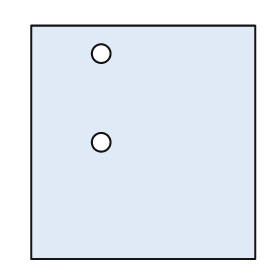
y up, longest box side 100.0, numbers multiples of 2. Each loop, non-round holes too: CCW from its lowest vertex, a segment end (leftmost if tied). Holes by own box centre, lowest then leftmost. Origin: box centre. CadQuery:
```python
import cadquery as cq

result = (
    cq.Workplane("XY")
    .moveTo(-48.0, -50.0)
    .lineTo(48.0, -50.0)
    .lineTo(48.0, 50.0)
    .lineTo(-48.0, 50.0)
    .close()
    .moveTo(-18.0, 0.0)
    .circle(4.0)
    .moveTo(-18.0, 38.0)
    .circle(4.0)
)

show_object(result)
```